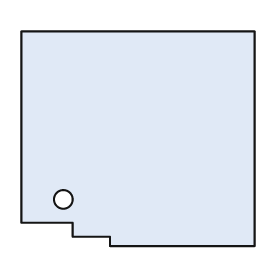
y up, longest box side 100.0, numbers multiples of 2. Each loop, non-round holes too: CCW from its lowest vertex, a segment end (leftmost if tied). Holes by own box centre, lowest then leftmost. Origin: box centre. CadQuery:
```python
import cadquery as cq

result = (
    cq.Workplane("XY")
    .moveTo(-12.0, -46.0)
    .lineTo(50.0, -46.0)
    .lineTo(50.0, 46.0)
    .lineTo(-50.0, 46.0)
    .lineTo(-50.0, -36.0)
    .lineTo(-28.0, -36.0)
    .lineTo(-28.0, -42.0)
    .lineTo(-12.0, -42.0)
    .close()
    .moveTo(-32.0, -26.0)
    .circle(4.0)
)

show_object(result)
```